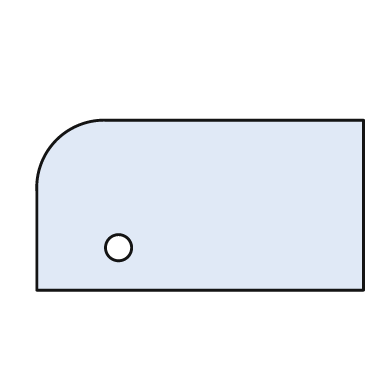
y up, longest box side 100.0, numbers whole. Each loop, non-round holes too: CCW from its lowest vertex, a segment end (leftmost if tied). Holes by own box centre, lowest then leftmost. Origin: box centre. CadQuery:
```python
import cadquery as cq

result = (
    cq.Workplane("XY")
    .moveTo(-50.0, -26.0)
    .lineTo(50.0, -26.0)
    .lineTo(50.0, 26.0)
    .lineTo(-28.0, 26.0)
    .threePointArc((-44.0, 20.0), (-50.0, 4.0))
    .close()
    .moveTo(-25.0, -13.0)
    .circle(4.0)
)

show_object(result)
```